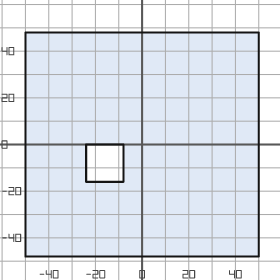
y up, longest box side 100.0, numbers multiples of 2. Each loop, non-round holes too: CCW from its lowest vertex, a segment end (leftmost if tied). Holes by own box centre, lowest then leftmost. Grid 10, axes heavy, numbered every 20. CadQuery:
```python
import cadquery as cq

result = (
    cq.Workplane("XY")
    .moveTo(-50.0, -48.0)
    .lineTo(50.0, -48.0)
    .lineTo(50.0, 48.0)
    .lineTo(-50.0, 48.0)
    .close()
    .moveTo(-24.0, -16.0)
    .lineTo(-8.0, -16.0)
    .lineTo(-8.0, 0.0)
    .lineTo(-24.0, 0.0)
    .close()
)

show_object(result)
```